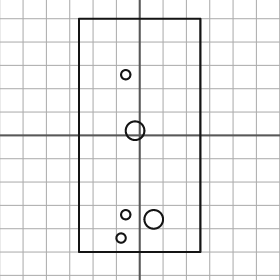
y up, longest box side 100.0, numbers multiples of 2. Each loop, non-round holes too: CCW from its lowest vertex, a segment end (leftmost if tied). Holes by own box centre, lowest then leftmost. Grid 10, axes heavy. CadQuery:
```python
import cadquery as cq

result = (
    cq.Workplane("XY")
    .moveTo(-26.0, -50.0)
    .lineTo(26.0, -50.0)
    .lineTo(26.0, 50.0)
    .lineTo(-26.0, 50.0)
    .close()
    .moveTo(-8.0, -44.0)
    .circle(2.0)
    .moveTo(6.0, -36.0)
    .circle(4.0)
    .moveTo(-6.0, -34.0)
    .circle(2.0)
    .moveTo(-2.0, 2.0)
    .circle(4.0)
    .moveTo(-6.0, 26.0)
    .circle(2.0)
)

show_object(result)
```